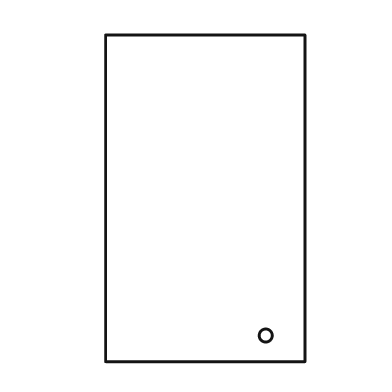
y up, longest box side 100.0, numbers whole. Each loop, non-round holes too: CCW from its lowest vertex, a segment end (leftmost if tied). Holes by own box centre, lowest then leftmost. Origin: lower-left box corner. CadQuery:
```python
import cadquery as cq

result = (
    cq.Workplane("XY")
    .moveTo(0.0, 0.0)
    .lineTo(61.0, 0.0)
    .lineTo(61.0, 100.0)
    .lineTo(0.0, 100.0)
    .close()
    .moveTo(49.0, 8.0)
    .circle(2.0)
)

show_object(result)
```